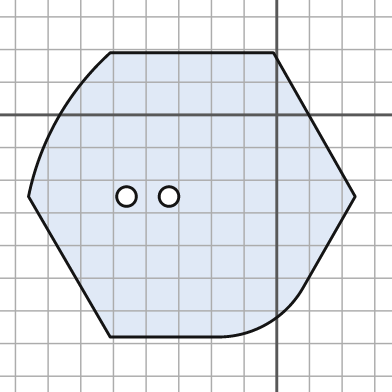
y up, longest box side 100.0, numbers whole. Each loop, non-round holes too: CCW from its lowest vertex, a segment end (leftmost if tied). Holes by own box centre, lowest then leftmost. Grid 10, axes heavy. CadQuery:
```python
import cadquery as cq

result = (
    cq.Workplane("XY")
    .moveTo(-51.0, -68.0)
    .lineTo(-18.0, -68.0)
    .threePointArc((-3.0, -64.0), (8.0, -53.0))
    .lineTo(24.0, -25.0)
    .lineTo(-1.0, 19.0)
    .lineTo(-51.0, 19.0)
    .threePointArc((-67.0, -1.0), (-76.0, -25.0))
    .close()
    .moveTo(-46.0, -25.0)
    .circle(3.0)
    .moveTo(-33.0, -25.0)
    .circle(3.0)
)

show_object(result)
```